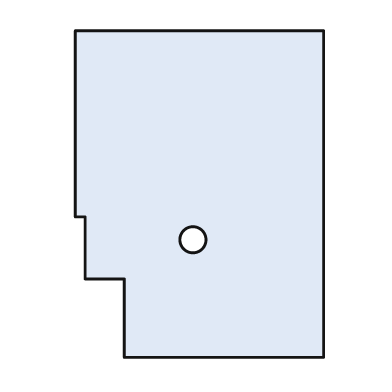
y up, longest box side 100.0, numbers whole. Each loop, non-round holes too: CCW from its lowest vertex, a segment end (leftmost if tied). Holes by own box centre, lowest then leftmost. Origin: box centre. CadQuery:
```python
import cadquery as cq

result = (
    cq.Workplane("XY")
    .moveTo(-23.0, -50.0)
    .lineTo(38.0, -50.0)
    .lineTo(38.0, 50.0)
    .lineTo(-38.0, 50.0)
    .lineTo(-38.0, -7.0)
    .lineTo(-35.0, -7.0)
    .lineTo(-35.0, -26.0)
    .lineTo(-23.0, -26.0)
    .close()
    .moveTo(-2.0, -14.0)
    .circle(4.0)
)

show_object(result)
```